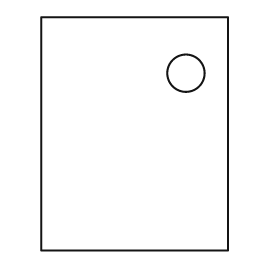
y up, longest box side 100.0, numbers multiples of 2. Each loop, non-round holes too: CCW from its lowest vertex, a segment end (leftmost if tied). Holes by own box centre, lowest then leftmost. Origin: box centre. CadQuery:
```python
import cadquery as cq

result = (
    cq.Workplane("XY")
    .moveTo(-40.0, -50.0)
    .lineTo(40.0, -50.0)
    .lineTo(40.0, 50.0)
    .lineTo(-40.0, 50.0)
    .close()
    .moveTo(22.0, 26.0)
    .circle(8.0)
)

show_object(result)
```